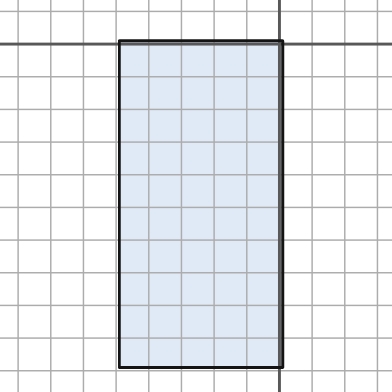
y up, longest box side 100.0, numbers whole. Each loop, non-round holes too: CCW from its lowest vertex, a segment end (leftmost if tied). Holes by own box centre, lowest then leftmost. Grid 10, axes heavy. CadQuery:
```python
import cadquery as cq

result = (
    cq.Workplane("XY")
    .moveTo(-49.0, -99.0)
    .lineTo(1.0, -99.0)
    .lineTo(1.0, 1.0)
    .lineTo(-49.0, 1.0)
    .close()
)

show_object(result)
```